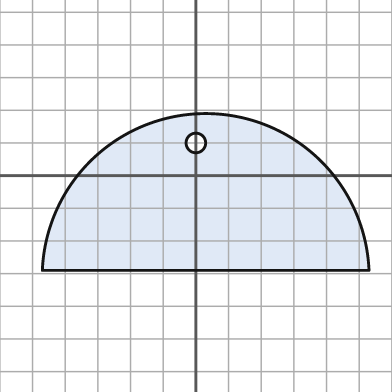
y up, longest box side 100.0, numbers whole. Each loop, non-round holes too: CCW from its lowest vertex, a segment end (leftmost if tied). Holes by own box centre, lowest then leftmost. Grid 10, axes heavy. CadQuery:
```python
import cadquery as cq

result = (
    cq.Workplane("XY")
    .moveTo(-47.0, -29.0)
    .lineTo(53.0, -29.0)
    .threePointArc((3.0, 19.0), (-47.0, -29.0))
    .close()
    .moveTo(0.0, 10.0)
    .circle(3.0)
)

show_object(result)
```